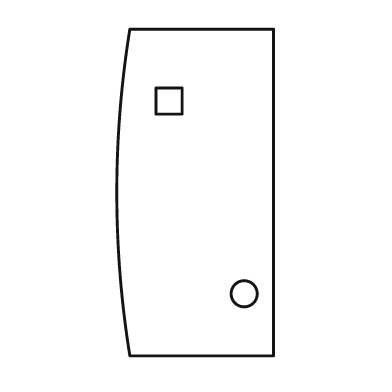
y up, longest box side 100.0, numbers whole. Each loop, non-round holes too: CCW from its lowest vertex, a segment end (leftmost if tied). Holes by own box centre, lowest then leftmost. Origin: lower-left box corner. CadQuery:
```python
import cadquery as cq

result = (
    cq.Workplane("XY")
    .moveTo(4.0, 0.0)
    .lineTo(48.0, 0.0)
    .lineTo(48.0, 100.0)
    .lineTo(4.0, 100.0)
    .threePointArc((0.0, 50.0), (4.0, 0.0))
    .close()
    .moveTo(39.0, 19.0)
    .circle(4.0)
    .moveTo(12.0, 74.0)
    .lineTo(20.0, 74.0)
    .lineTo(20.0, 82.0)
    .lineTo(12.0, 82.0)
    .close()
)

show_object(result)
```